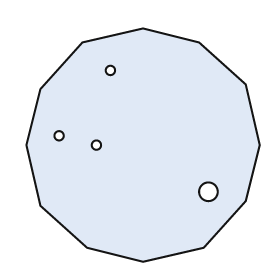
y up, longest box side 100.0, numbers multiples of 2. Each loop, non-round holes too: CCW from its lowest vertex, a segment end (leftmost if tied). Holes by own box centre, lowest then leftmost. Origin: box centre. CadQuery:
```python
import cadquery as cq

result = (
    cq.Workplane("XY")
    .moveTo(0.0, -50.0)
    .lineTo(26.0, -44.0)
    .lineTo(44.0, -24.0)
    .lineTo(50.0, 0.0)
    .lineTo(44.0, 26.0)
    .lineTo(24.0, 44.0)
    .lineTo(0.0, 50.0)
    .lineTo(-26.0, 44.0)
    .lineTo(-44.0, 24.0)
    .lineTo(-50.0, 0.0)
    .lineTo(-44.0, -26.0)
    .lineTo(-24.0, -44.0)
    .close()
    .moveTo(28.0, -20.0)
    .circle(4.0)
    .moveTo(-20.0, 0.0)
    .circle(2.0)
    .moveTo(-36.0, 4.0)
    .circle(2.0)
    .moveTo(-14.0, 32.0)
    .circle(2.0)
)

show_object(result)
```